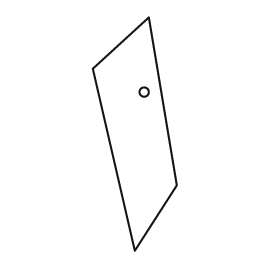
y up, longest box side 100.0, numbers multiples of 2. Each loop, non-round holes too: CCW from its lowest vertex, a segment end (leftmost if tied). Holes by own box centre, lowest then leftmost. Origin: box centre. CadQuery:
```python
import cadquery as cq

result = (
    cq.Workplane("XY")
    .moveTo(0.0, -50.0)
    .lineTo(18.0, -22.0)
    .lineTo(6.0, 50.0)
    .lineTo(-18.0, 28.0)
    .close()
    .moveTo(4.0, 18.0)
    .circle(2.0)
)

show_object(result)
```